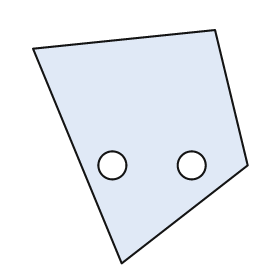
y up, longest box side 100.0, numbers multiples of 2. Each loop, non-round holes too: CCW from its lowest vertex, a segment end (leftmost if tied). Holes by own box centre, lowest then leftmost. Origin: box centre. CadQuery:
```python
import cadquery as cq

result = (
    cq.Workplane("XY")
    .moveTo(-8.0, -50.0)
    .lineTo(46.0, -8.0)
    .lineTo(32.0, 50.0)
    .lineTo(-46.0, 42.0)
    .close()
    .moveTo(-12.0, -8.0)
    .circle(6.0)
    .moveTo(22.0, -8.0)
    .circle(6.0)
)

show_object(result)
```